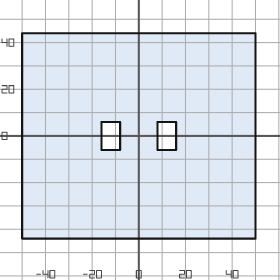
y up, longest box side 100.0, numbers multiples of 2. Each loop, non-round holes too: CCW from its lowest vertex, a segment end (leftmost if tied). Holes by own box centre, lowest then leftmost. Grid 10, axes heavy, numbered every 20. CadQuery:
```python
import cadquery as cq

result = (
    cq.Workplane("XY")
    .moveTo(-50.0, -44.0)
    .lineTo(50.0, -44.0)
    .lineTo(50.0, 44.0)
    .lineTo(-50.0, 44.0)
    .close()
    .moveTo(-16.0, -6.0)
    .lineTo(-8.0, -6.0)
    .lineTo(-8.0, 6.0)
    .lineTo(-16.0, 6.0)
    .close()
    .moveTo(8.0, -6.0)
    .lineTo(16.0, -6.0)
    .lineTo(16.0, 6.0)
    .lineTo(8.0, 6.0)
    .close()
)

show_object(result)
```